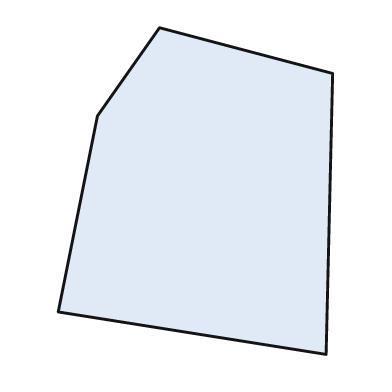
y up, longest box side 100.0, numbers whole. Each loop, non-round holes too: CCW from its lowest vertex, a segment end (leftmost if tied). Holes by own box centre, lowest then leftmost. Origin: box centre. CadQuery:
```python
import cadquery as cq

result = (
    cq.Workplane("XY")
    .moveTo(40.0, -50.0)
    .lineTo(42.0, 36.0)
    .lineTo(-11.0, 50.0)
    .lineTo(-30.0, 23.0)
    .lineTo(-42.0, -37.0)
    .close()
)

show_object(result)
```